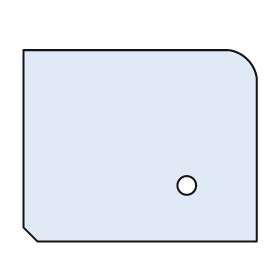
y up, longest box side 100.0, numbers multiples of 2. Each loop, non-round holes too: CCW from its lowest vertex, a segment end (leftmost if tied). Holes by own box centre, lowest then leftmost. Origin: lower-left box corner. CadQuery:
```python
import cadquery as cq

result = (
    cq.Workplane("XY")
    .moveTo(6.0, 0.0)
    .lineTo(100.0, 0.0)
    .lineTo(100.0, 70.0)
    .threePointArc((96.0, 78.0), (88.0, 82.0))
    .lineTo(0.0, 82.0)
    .lineTo(0.0, 6.0)
    .close()
    .moveTo(70.0, 24.0)
    .circle(4.0)
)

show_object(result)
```